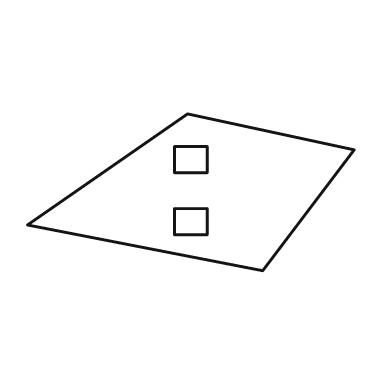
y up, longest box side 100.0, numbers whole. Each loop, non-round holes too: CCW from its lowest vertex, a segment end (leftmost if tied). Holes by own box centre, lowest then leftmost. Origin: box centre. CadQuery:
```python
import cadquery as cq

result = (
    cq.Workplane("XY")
    .moveTo(22.0, -24.0)
    .lineTo(50.0, 13.0)
    .lineTo(-1.0, 24.0)
    .lineTo(-50.0, -10.0)
    .close()
    .moveTo(-5.0, -13.0)
    .lineTo(5.0, -13.0)
    .lineTo(5.0, -5.0)
    .lineTo(-5.0, -5.0)
    .close()
    .moveTo(-5.0, 6.0)
    .lineTo(5.0, 6.0)
    .lineTo(5.0, 14.0)
    .lineTo(-5.0, 14.0)
    .close()
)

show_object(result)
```